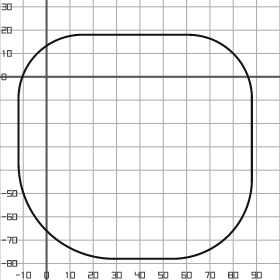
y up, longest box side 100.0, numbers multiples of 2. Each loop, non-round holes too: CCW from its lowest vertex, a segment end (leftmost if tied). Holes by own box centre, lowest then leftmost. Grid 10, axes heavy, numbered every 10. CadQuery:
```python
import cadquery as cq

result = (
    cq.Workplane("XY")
    .moveTo(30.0, -78.0)
    .lineTo(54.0, -78.0)
    .threePointArc((78.0, -68.0), (88.0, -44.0))
    .lineTo(88.0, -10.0)
    .threePointArc((80.0, 10.0), (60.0, 18.0))
    .lineTo(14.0, 18.0)
    .threePointArc((-4.0, 10.0), (-12.0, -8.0))
    .lineTo(-12.0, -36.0)
    .threePointArc((0.0, -66.0), (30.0, -78.0))
    .close()
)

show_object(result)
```